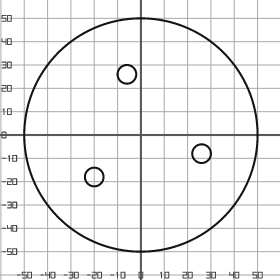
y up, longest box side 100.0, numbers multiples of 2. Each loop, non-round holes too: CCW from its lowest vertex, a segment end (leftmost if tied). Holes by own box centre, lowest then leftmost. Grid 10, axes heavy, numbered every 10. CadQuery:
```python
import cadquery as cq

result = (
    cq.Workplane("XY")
    .moveTo(0.0, 0.0)
    .circle(50.0)
    .moveTo(-20.0, -18.0)
    .circle(4.0)
    .moveTo(26.0, -8.0)
    .circle(4.0)
    .moveTo(-6.0, 26.0)
    .circle(4.0)
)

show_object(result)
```